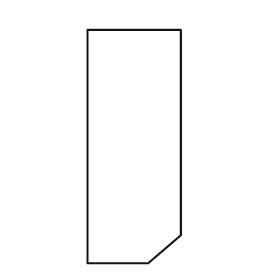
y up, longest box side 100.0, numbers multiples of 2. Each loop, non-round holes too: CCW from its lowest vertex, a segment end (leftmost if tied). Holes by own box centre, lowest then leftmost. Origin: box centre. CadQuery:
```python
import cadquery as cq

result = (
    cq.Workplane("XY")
    .moveTo(-20.0, -50.0)
    .lineTo(6.0, -50.0)
    .lineTo(20.0, -38.0)
    .lineTo(20.0, 50.0)
    .lineTo(-20.0, 50.0)
    .close()
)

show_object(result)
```